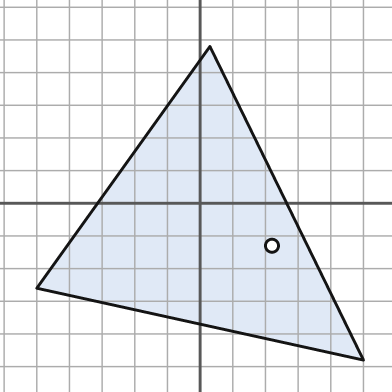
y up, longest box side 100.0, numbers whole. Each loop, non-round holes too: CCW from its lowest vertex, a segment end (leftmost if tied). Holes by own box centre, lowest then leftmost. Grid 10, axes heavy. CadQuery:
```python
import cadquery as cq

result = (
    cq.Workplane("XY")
    .moveTo(50.0, -48.0)
    .lineTo(3.0, 48.0)
    .lineTo(-50.0, -26.0)
    .close()
    .moveTo(22.0, -13.0)
    .circle(2.0)
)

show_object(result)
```